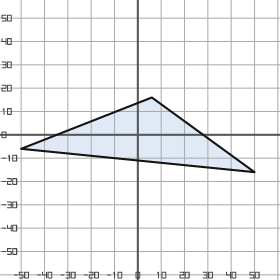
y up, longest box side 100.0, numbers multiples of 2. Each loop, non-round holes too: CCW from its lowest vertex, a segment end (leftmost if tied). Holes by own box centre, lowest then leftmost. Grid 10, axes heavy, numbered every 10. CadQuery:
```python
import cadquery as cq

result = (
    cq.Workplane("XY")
    .moveTo(50.0, -16.0)
    .lineTo(6.0, 16.0)
    .lineTo(-50.0, -6.0)
    .close()
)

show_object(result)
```